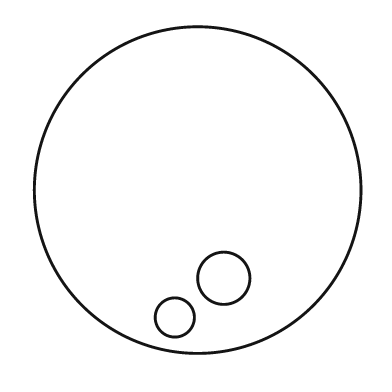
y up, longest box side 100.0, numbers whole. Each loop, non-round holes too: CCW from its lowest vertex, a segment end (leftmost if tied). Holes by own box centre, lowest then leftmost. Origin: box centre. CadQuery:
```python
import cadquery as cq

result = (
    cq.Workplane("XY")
    .moveTo(0.0, 0.0)
    .circle(50.0)
    .moveTo(-7.0, -39.0)
    .circle(6.0)
    .moveTo(8.0, -27.0)
    .circle(8.0)
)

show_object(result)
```